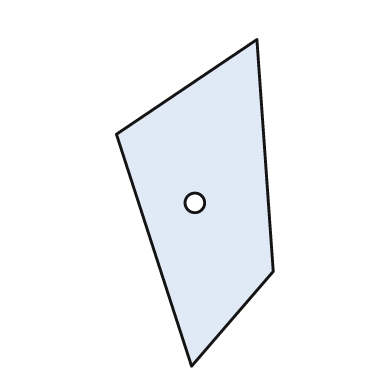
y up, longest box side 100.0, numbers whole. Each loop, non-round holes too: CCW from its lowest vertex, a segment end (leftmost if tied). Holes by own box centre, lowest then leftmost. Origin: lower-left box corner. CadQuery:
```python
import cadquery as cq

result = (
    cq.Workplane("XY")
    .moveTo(23.0, 0.0)
    .lineTo(48.0, 29.0)
    .lineTo(43.0, 100.0)
    .lineTo(0.0, 71.0)
    .close()
    .moveTo(24.0, 50.0)
    .circle(3.0)
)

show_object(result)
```